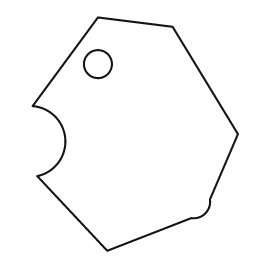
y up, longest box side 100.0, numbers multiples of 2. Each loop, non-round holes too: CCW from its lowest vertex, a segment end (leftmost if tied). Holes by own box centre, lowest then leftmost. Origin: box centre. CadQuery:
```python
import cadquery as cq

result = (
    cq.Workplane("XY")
    .moveTo(-12.0, -50.0)
    .lineTo(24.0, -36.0)
    .threePointArc((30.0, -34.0), (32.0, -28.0))
    .lineTo(44.0, 0.0)
    .lineTo(16.0, 46.0)
    .lineTo(-16.0, 50.0)
    .lineTo(-44.0, 12.0)
    .threePointArc((-30.0, -2.0), (-42.0, -18.0))
    .close()
    .moveTo(-16.0, 30.0)
    .circle(6.0)
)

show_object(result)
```